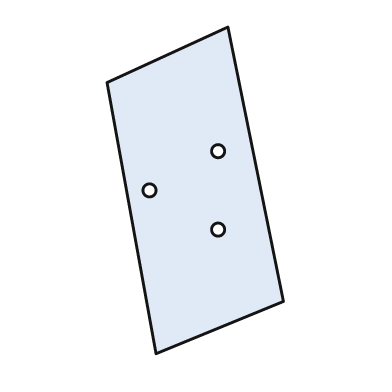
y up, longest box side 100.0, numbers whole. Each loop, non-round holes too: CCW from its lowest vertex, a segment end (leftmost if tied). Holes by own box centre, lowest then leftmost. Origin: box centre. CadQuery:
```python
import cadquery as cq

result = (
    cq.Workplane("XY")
    .moveTo(-12.0, -50.0)
    .lineTo(27.0, -34.0)
    .lineTo(10.0, 50.0)
    .lineTo(-27.0, 33.0)
    .close()
    .moveTo(7.0, -12.0)
    .circle(2.0)
    .moveTo(-14.0, 0.0)
    .circle(2.0)
    .moveTo(7.0, 12.0)
    .circle(2.0)
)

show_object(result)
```